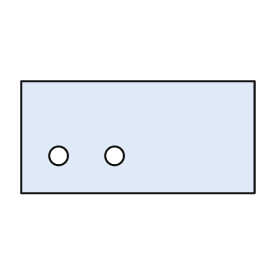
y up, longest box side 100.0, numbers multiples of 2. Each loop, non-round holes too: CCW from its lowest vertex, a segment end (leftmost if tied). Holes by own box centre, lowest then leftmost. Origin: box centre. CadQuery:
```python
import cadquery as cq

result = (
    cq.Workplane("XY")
    .moveTo(-50.0, -24.0)
    .lineTo(50.0, -24.0)
    .lineTo(50.0, 24.0)
    .lineTo(-50.0, 24.0)
    .close()
    .moveTo(-34.0, -8.0)
    .circle(4.0)
    .moveTo(-10.0, -8.0)
    .circle(4.0)
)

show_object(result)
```